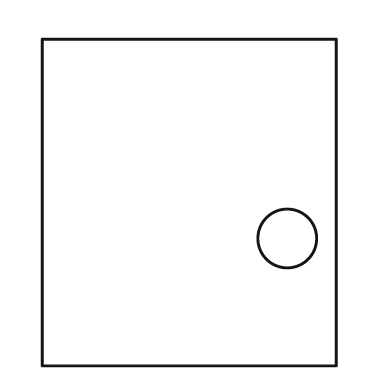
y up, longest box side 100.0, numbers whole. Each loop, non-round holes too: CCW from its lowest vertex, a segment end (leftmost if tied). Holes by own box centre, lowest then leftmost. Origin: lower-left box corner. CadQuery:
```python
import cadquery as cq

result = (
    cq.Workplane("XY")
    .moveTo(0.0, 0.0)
    .lineTo(90.0, 0.0)
    .lineTo(90.0, 100.0)
    .lineTo(0.0, 100.0)
    .close()
    .moveTo(75.0, 39.0)
    .circle(9.0)
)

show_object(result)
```